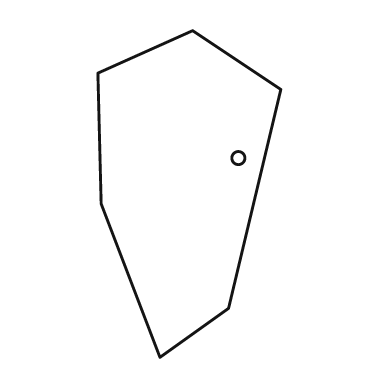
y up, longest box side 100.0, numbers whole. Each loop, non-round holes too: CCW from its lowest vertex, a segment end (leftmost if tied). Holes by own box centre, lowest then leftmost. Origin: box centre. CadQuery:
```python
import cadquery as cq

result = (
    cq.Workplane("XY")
    .moveTo(-9.0, -50.0)
    .lineTo(12.0, -35.0)
    .lineTo(28.0, 32.0)
    .lineTo(1.0, 50.0)
    .lineTo(-28.0, 37.0)
    .lineTo(-27.0, -3.0)
    .close()
    .moveTo(15.0, 11.0)
    .circle(2.0)
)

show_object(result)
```